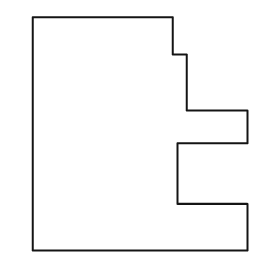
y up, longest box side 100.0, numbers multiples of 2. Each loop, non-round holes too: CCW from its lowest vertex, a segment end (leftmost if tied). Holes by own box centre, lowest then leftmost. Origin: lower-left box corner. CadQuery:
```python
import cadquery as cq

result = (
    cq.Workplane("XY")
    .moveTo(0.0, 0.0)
    .lineTo(92.0, 0.0)
    .lineTo(92.0, 20.0)
    .lineTo(62.0, 20.0)
    .lineTo(62.0, 46.0)
    .lineTo(92.0, 46.0)
    .lineTo(92.0, 60.0)
    .lineTo(66.0, 60.0)
    .lineTo(66.0, 84.0)
    .lineTo(60.0, 84.0)
    .lineTo(60.0, 100.0)
    .lineTo(0.0, 100.0)
    .close()
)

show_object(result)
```